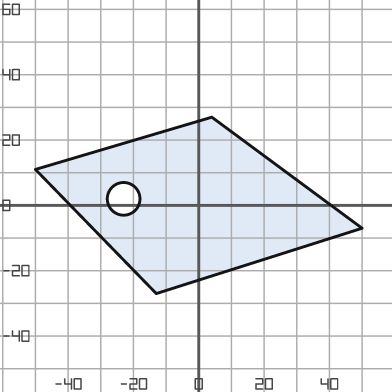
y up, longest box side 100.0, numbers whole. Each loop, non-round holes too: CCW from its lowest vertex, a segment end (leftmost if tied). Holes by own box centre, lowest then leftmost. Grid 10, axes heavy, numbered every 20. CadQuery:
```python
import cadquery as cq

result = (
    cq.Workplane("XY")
    .moveTo(-13.0, -27.0)
    .lineTo(50.0, -7.0)
    .lineTo(4.0, 27.0)
    .lineTo(-50.0, 11.0)
    .close()
    .moveTo(-23.0, 2.0)
    .circle(5.0)
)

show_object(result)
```